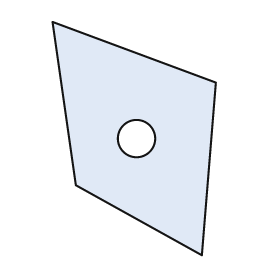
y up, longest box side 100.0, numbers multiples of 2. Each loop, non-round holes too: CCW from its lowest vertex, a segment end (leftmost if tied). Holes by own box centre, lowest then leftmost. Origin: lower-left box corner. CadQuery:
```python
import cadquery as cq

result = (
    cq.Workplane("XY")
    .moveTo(64.0, 0.0)
    .lineTo(70.0, 74.0)
    .lineTo(0.0, 100.0)
    .lineTo(10.0, 30.0)
    .close()
    .moveTo(36.0, 50.0)
    .circle(8.0)
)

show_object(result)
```